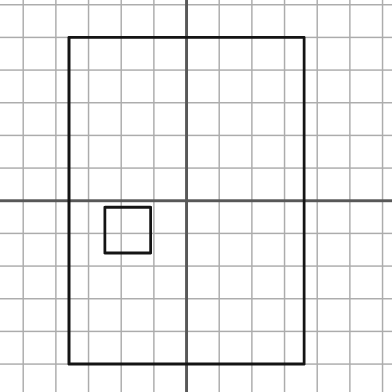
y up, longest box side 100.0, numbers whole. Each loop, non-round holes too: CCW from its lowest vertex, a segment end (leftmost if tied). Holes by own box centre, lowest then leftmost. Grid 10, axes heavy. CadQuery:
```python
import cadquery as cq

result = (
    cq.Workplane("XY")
    .moveTo(-36.0, -50.0)
    .lineTo(36.0, -50.0)
    .lineTo(36.0, 50.0)
    .lineTo(-36.0, 50.0)
    .close()
    .moveTo(-25.0, -16.0)
    .lineTo(-11.0, -16.0)
    .lineTo(-11.0, -2.0)
    .lineTo(-25.0, -2.0)
    .close()
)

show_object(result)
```